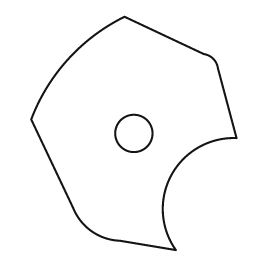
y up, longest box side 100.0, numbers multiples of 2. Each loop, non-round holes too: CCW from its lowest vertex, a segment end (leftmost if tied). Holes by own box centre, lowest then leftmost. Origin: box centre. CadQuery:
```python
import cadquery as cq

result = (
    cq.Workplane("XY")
    .moveTo(18.0, -50.0)
    .threePointArc((16.0, -18.0), (44.0, -2.0))
    .lineTo(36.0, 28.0)
    .threePointArc((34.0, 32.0), (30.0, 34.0))
    .lineTo(-4.0, 50.0)
    .threePointArc((-28.0, 32.0), (-44.0, 6.0))
    .lineTo(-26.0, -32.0)
    .threePointArc((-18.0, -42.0), (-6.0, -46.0))
    .close()
    .moveTo(0.0, 0.0)
    .circle(8.0)
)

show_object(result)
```